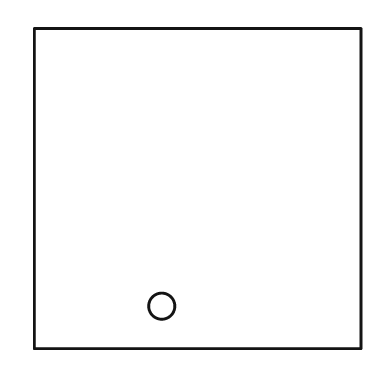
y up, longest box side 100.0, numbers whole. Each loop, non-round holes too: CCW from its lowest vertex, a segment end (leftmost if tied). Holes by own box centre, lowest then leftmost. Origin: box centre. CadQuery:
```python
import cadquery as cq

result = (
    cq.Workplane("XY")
    .moveTo(-50.0, -49.0)
    .lineTo(50.0, -49.0)
    .lineTo(50.0, 49.0)
    .lineTo(-50.0, 49.0)
    .close()
    .moveTo(-11.0, -36.0)
    .circle(4.0)
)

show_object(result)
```